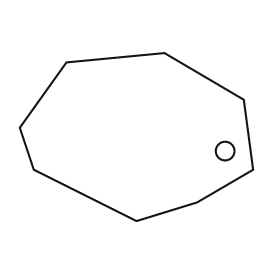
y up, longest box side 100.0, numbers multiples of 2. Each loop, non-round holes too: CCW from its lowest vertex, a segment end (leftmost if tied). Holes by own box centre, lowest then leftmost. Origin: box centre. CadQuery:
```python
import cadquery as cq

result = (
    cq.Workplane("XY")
    .moveTo(0.0, -36.0)
    .lineTo(26.0, -28.0)
    .lineTo(50.0, -14.0)
    .lineTo(46.0, 16.0)
    .lineTo(12.0, 36.0)
    .lineTo(-30.0, 32.0)
    .lineTo(-50.0, 4.0)
    .lineTo(-44.0, -14.0)
    .close()
    .moveTo(38.0, -6.0)
    .circle(4.0)
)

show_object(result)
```